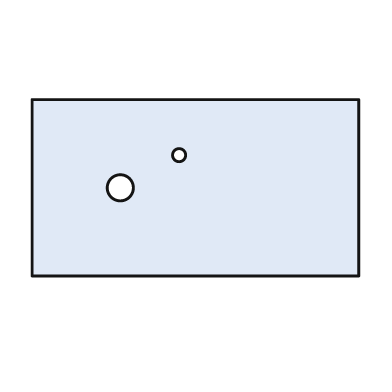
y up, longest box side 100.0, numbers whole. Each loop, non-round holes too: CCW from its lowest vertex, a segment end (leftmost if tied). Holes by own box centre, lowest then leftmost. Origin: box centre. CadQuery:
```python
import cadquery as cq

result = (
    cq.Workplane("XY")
    .moveTo(-50.0, -27.0)
    .lineTo(50.0, -27.0)
    .lineTo(50.0, 27.0)
    .lineTo(-50.0, 27.0)
    .close()
    .moveTo(-23.0, 0.0)
    .circle(4.0)
    .moveTo(-5.0, 10.0)
    .circle(2.0)
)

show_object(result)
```